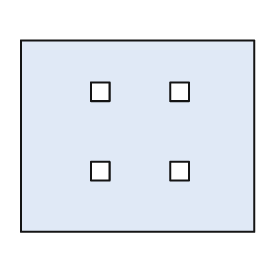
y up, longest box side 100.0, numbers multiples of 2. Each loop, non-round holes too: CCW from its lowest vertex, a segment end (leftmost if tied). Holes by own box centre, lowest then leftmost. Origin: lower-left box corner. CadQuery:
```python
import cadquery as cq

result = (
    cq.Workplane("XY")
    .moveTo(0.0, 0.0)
    .lineTo(100.0, 0.0)
    .lineTo(100.0, 82.0)
    .lineTo(0.0, 82.0)
    .close()
    .moveTo(30.0, 22.0)
    .lineTo(38.0, 22.0)
    .lineTo(38.0, 30.0)
    .lineTo(30.0, 30.0)
    .close()
    .moveTo(64.0, 22.0)
    .lineTo(72.0, 22.0)
    .lineTo(72.0, 30.0)
    .lineTo(64.0, 30.0)
    .close()
    .moveTo(30.0, 56.0)
    .lineTo(38.0, 56.0)
    .lineTo(38.0, 64.0)
    .lineTo(30.0, 64.0)
    .close()
    .moveTo(64.0, 56.0)
    .lineTo(72.0, 56.0)
    .lineTo(72.0, 64.0)
    .lineTo(64.0, 64.0)
    .close()
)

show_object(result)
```